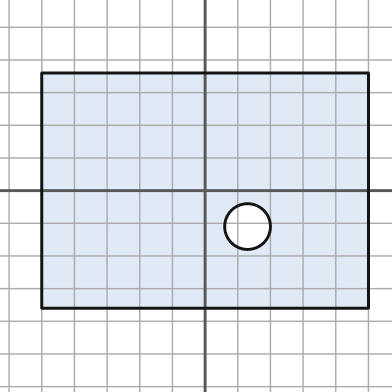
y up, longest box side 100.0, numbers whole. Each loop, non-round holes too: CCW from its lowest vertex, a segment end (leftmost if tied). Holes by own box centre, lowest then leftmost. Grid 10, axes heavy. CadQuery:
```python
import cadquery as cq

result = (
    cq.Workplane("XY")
    .moveTo(-50.0, -36.0)
    .lineTo(50.0, -36.0)
    .lineTo(50.0, 36.0)
    .lineTo(-50.0, 36.0)
    .close()
    .moveTo(13.0, -11.0)
    .circle(7.0)
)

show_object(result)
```